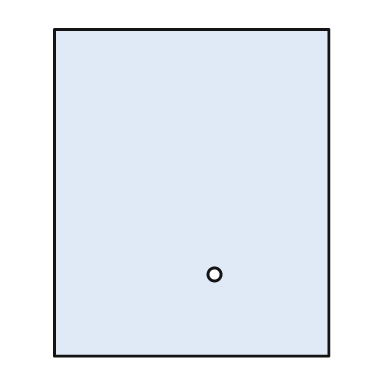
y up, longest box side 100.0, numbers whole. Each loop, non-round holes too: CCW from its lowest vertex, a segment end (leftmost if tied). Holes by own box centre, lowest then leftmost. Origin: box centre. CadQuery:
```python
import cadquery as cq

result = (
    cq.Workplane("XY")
    .moveTo(-42.0, -50.0)
    .lineTo(42.0, -50.0)
    .lineTo(42.0, 50.0)
    .lineTo(-42.0, 50.0)
    .close()
    .moveTo(7.0, -25.0)
    .circle(2.0)
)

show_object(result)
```